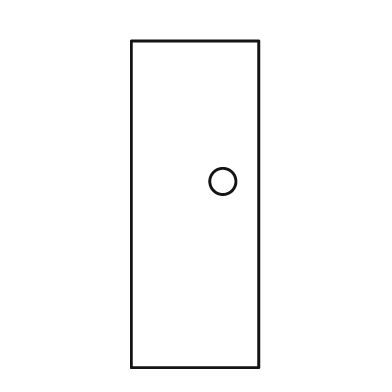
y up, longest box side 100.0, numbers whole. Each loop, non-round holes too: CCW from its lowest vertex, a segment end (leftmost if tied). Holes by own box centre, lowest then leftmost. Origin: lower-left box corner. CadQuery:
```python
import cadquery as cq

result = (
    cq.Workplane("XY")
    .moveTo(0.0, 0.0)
    .lineTo(39.0, 0.0)
    .lineTo(39.0, 100.0)
    .lineTo(0.0, 100.0)
    .close()
    .moveTo(28.0, 57.0)
    .circle(4.0)
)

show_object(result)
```